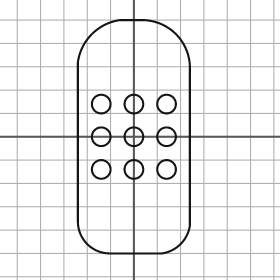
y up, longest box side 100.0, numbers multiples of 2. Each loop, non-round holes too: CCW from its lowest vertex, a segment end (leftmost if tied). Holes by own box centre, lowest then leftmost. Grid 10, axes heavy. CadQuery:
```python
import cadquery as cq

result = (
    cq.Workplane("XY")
    .moveTo(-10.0, -50.0)
    .lineTo(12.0, -50.0)
    .threePointArc((20.0, -46.0), (24.0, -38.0))
    .lineTo(24.0, 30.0)
    .threePointArc((18.0, 44.0), (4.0, 50.0))
    .lineTo(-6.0, 50.0)
    .threePointArc((-18.0, 44.0), (-24.0, 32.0))
    .lineTo(-24.0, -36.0)
    .threePointArc((-20.0, -46.0), (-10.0, -50.0))
    .close()
    .moveTo(-14.0, -14.0)
    .circle(4.0)
    .moveTo(0.0, -14.0)
    .circle(4.0)
    .moveTo(14.0, -14.0)
    .circle(4.0)
    .moveTo(-14.0, 0.0)
    .circle(4.0)
    .moveTo(0.0, 0.0)
    .circle(4.0)
    .moveTo(14.0, 0.0)
    .circle(4.0)
    .moveTo(-14.0, 14.0)
    .circle(4.0)
    .moveTo(0.0, 14.0)
    .circle(4.0)
    .moveTo(14.0, 14.0)
    .circle(4.0)
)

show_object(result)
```